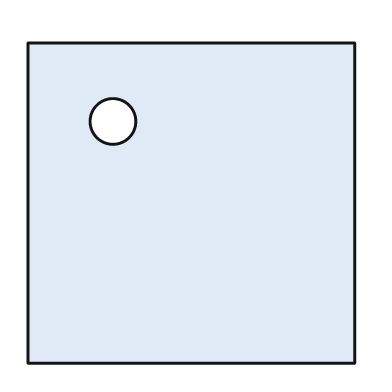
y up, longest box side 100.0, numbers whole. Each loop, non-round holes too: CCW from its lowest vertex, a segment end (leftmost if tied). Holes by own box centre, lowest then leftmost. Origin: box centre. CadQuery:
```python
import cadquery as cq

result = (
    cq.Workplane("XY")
    .moveTo(-50.0, -49.0)
    .lineTo(50.0, -49.0)
    .lineTo(50.0, 49.0)
    .lineTo(-50.0, 49.0)
    .close()
    .moveTo(-24.0, 25.0)
    .circle(7.0)
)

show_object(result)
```